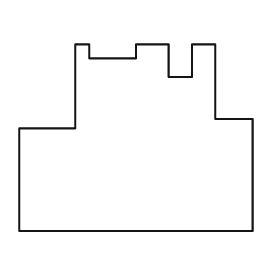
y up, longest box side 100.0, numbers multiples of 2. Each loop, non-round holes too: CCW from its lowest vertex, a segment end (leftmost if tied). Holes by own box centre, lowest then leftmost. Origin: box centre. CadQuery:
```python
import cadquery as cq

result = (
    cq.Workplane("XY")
    .moveTo(-50.0, -40.0)
    .lineTo(50.0, -40.0)
    .lineTo(50.0, 8.0)
    .lineTo(34.0, 8.0)
    .lineTo(34.0, 40.0)
    .lineTo(24.0, 40.0)
    .lineTo(24.0, 26.0)
    .lineTo(14.0, 26.0)
    .lineTo(14.0, 40.0)
    .lineTo(0.0, 40.0)
    .lineTo(0.0, 34.0)
    .lineTo(-20.0, 34.0)
    .lineTo(-20.0, 40.0)
    .lineTo(-26.0, 40.0)
    .lineTo(-26.0, 4.0)
    .lineTo(-50.0, 4.0)
    .close()
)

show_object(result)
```